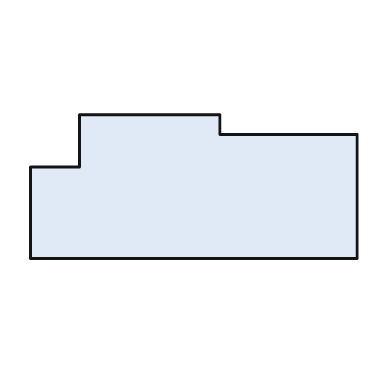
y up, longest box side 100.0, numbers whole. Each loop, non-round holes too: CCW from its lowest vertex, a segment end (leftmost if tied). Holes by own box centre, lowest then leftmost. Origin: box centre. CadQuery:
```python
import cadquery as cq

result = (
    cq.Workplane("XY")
    .moveTo(-50.0, -22.0)
    .lineTo(50.0, -22.0)
    .lineTo(50.0, 16.0)
    .lineTo(8.0, 16.0)
    .lineTo(8.0, 22.0)
    .lineTo(-35.0, 22.0)
    .lineTo(-35.0, 6.0)
    .lineTo(-50.0, 6.0)
    .close()
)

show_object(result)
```